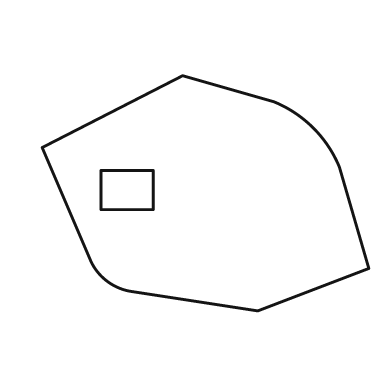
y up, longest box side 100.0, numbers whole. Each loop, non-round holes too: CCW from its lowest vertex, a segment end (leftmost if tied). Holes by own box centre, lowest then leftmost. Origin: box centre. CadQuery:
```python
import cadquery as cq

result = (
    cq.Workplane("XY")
    .moveTo(16.0, -36.0)
    .lineTo(50.0, -23.0)
    .lineTo(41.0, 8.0)
    .threePointArc((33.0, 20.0), (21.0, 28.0))
    .lineTo(-7.0, 36.0)
    .lineTo(-50.0, 14.0)
    .lineTo(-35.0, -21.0)
    .threePointArc((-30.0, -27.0), (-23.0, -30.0))
    .close()
    .moveTo(-32.0, -5.0)
    .lineTo(-16.0, -5.0)
    .lineTo(-16.0, 7.0)
    .lineTo(-32.0, 7.0)
    .close()
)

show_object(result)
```